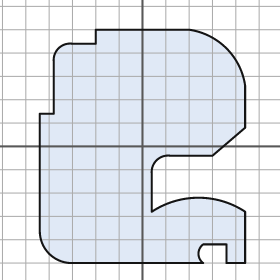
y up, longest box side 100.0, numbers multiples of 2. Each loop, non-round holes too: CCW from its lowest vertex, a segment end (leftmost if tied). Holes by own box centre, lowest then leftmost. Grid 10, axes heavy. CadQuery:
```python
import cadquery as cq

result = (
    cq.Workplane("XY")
    .moveTo(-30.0, -50.0)
    .lineTo(26.0, -50.0)
    .threePointArc((24.0, -46.0), (26.0, -42.0))
    .lineTo(36.0, -42.0)
    .lineTo(36.0, -50.0)
    .lineTo(44.0, -50.0)
    .lineTo(44.0, -28.0)
    .threePointArc((24.0, -22.0), (4.0, -28.0))
    .lineTo(4.0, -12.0)
    .threePointArc((6.0, -6.0), (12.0, -4.0))
    .lineTo(30.0, -4.0)
    .lineTo(44.0, 8.0)
    .lineTo(44.0, 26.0)
    .threePointArc((36.0, 42.0), (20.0, 50.0))
    .lineTo(-20.0, 50.0)
    .lineTo(-20.0, 44.0)
    .lineTo(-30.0, 44.0)
    .threePointArc((-36.0, 42.0), (-38.0, 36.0))
    .lineTo(-38.0, 14.0)
    .lineTo(-44.0, 14.0)
    .lineTo(-44.0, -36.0)
    .threePointArc((-40.0, -46.0), (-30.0, -50.0))
    .close()
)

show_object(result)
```